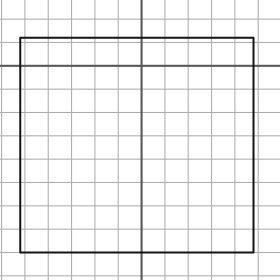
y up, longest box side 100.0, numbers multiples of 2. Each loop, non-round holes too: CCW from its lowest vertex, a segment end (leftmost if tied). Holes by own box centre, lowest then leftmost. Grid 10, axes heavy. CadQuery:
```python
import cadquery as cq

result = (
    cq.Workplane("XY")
    .moveTo(-52.0, -80.0)
    .lineTo(48.0, -80.0)
    .lineTo(48.0, 12.0)
    .lineTo(-52.0, 12.0)
    .close()
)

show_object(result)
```